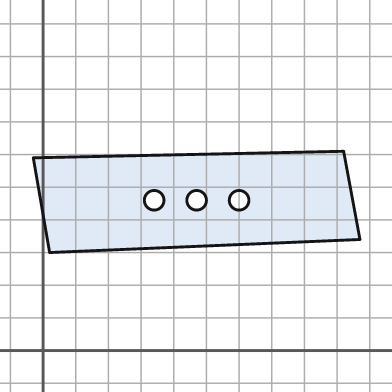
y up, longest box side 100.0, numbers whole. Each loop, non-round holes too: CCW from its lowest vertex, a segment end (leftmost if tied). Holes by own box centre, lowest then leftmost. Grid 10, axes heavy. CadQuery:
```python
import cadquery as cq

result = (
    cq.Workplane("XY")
    .moveTo(2.0, 30.0)
    .lineTo(97.0, 34.0)
    .lineTo(92.0, 61.0)
    .lineTo(-3.0, 59.0)
    .close()
    .moveTo(34.0, 46.0)
    .circle(3.0)
    .moveTo(47.0, 46.0)
    .circle(3.0)
    .moveTo(60.0, 46.0)
    .circle(3.0)
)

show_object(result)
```